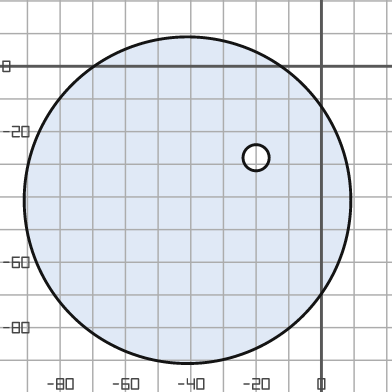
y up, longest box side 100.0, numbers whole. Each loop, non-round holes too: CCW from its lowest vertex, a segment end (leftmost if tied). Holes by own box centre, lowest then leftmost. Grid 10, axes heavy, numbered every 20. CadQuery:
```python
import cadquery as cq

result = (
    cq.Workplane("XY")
    .moveTo(-41.0, -41.0)
    .circle(50.0)
    .moveTo(-20.0, -28.0)
    .circle(4.0)
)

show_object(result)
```